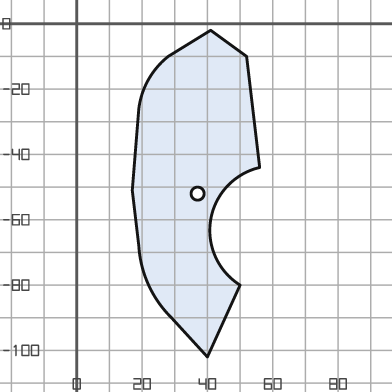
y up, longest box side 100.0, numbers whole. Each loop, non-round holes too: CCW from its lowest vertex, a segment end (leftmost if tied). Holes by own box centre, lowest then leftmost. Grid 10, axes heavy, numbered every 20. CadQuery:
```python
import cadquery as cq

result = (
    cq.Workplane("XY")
    .moveTo(40.0, -102.0)
    .lineTo(50.0, -80.0)
    .threePointArc((41.0, -60.0), (56.0, -44.0))
    .lineTo(52.0, -10.0)
    .lineTo(41.0, -2.0)
    .lineTo(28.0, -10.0)
    .threePointArc((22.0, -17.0), (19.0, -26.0))
    .lineTo(17.0, -51.0)
    .lineTo(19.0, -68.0)
    .threePointArc((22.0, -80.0), (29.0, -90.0))
    .close()
    .moveTo(37.0, -52.0)
    .circle(2.0)
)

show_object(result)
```